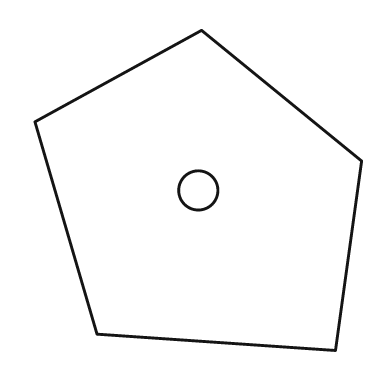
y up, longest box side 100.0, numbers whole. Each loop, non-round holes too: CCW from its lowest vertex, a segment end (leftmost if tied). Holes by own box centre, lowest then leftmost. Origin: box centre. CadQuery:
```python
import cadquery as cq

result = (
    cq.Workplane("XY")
    .moveTo(42.0, -49.0)
    .lineTo(50.0, 9.0)
    .lineTo(1.0, 49.0)
    .lineTo(-50.0, 21.0)
    .lineTo(-31.0, -44.0)
    .close()
    .moveTo(0.0, 0.0)
    .circle(6.0)
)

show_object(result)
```